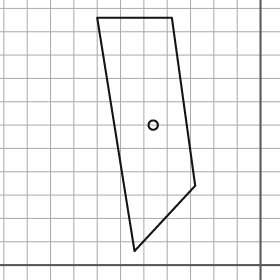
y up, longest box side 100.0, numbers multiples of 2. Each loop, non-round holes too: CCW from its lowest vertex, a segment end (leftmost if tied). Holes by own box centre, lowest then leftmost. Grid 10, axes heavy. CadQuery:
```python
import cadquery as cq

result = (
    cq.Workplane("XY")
    .moveTo(-54.0, 6.0)
    .lineTo(-28.0, 34.0)
    .lineTo(-38.0, 106.0)
    .lineTo(-70.0, 106.0)
    .close()
    .moveTo(-46.0, 60.0)
    .circle(2.0)
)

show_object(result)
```